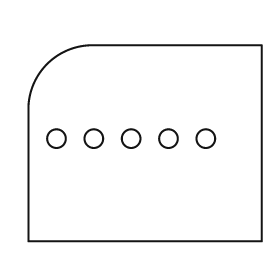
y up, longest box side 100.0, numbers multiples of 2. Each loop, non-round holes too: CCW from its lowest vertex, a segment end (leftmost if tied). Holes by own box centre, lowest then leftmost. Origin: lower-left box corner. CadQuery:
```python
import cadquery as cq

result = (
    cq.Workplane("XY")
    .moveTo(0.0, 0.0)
    .lineTo(100.0, 0.0)
    .lineTo(100.0, 84.0)
    .lineTo(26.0, 84.0)
    .threePointArc((8.0, 76.0), (0.0, 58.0))
    .close()
    .moveTo(12.0, 44.0)
    .circle(4.0)
    .moveTo(28.0, 44.0)
    .circle(4.0)
    .moveTo(44.0, 44.0)
    .circle(4.0)
    .moveTo(60.0, 44.0)
    .circle(4.0)
    .moveTo(76.0, 44.0)
    .circle(4.0)
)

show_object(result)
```